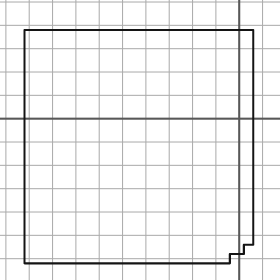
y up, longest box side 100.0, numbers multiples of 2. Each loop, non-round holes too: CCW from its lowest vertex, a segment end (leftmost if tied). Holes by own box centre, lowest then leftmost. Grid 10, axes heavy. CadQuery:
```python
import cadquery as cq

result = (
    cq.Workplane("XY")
    .moveTo(-92.0, -62.0)
    .lineTo(-4.0, -62.0)
    .lineTo(-4.0, -58.0)
    .lineTo(2.0, -58.0)
    .lineTo(2.0, -54.0)
    .lineTo(6.0, -54.0)
    .lineTo(6.0, 38.0)
    .lineTo(-92.0, 38.0)
    .close()
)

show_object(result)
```